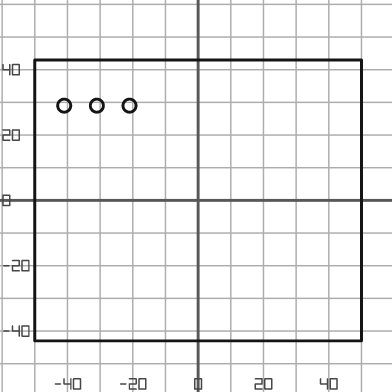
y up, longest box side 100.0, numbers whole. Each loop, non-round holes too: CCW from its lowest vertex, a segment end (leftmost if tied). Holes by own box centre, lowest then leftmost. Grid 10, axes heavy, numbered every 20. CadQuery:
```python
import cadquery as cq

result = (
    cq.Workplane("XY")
    .moveTo(-50.0, -43.0)
    .lineTo(50.0, -43.0)
    .lineTo(50.0, 43.0)
    .lineTo(-50.0, 43.0)
    .close()
    .moveTo(-41.0, 29.0)
    .circle(2.0)
    .moveTo(-31.0, 29.0)
    .circle(2.0)
    .moveTo(-21.0, 29.0)
    .circle(2.0)
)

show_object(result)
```